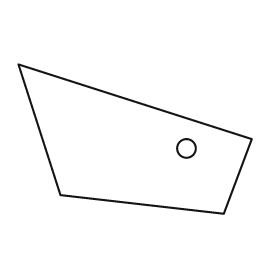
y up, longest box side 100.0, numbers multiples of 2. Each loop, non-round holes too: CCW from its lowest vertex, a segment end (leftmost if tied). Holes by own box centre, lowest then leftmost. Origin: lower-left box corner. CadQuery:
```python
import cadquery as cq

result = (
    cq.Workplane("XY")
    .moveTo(88.0, 0.0)
    .lineTo(100.0, 32.0)
    .lineTo(0.0, 64.0)
    .lineTo(18.0, 8.0)
    .close()
    .moveTo(72.0, 28.0)
    .circle(4.0)
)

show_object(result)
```